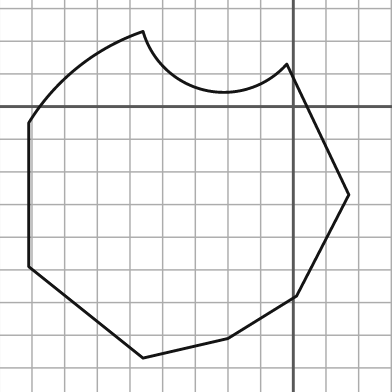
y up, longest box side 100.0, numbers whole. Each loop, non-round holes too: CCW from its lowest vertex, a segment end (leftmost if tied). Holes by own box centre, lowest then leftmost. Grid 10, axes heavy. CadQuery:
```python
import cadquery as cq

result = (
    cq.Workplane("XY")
    .moveTo(-46.0, -77.0)
    .lineTo(-20.0, -71.0)
    .lineTo(1.0, -58.0)
    .lineTo(17.0, -27.0)
    .lineTo(-2.0, 13.0)
    .threePointArc((-27.0, 5.0), (-46.0, 23.0))
    .threePointArc((-66.0, 12.0), (-81.0, -5.0))
    .lineTo(-81.0, -49.0)
    .close()
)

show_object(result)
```